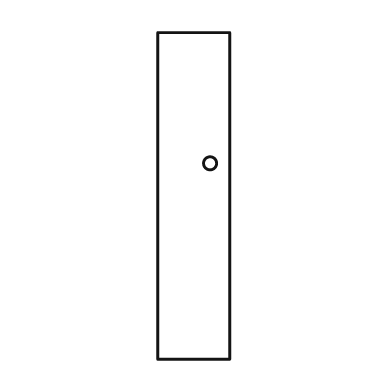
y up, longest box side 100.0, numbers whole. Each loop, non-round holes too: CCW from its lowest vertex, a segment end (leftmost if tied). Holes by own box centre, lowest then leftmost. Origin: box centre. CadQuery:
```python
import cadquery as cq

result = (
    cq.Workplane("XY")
    .moveTo(-11.0, -50.0)
    .lineTo(11.0, -50.0)
    .lineTo(11.0, 50.0)
    .lineTo(-11.0, 50.0)
    .close()
    .moveTo(5.0, 10.0)
    .circle(2.0)
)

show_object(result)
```